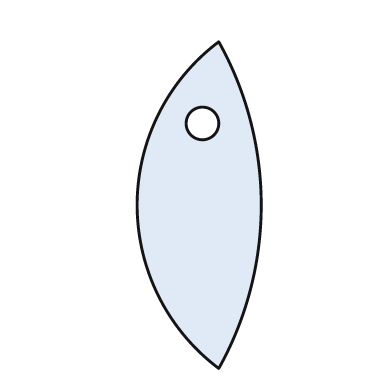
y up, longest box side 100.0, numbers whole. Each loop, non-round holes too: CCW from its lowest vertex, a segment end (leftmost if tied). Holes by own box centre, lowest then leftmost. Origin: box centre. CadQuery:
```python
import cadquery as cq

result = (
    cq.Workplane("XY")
    .moveTo(6.0, -50.0)
    .threePointArc((19.0, 0.0), (6.0, 50.0))
    .threePointArc((-19.0, 0.0), (6.0, -50.0))
    .close()
    .moveTo(1.0, 25.0)
    .circle(5.0)
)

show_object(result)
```